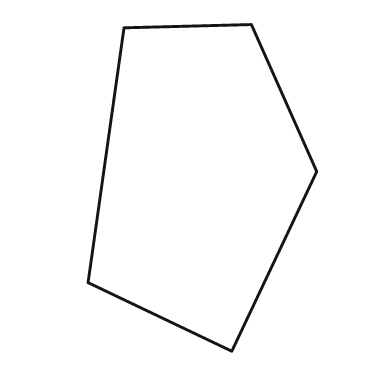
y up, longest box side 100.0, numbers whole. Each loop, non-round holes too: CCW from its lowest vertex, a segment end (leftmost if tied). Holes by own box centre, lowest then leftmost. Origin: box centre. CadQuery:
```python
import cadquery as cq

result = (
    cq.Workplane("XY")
    .moveTo(9.0, -50.0)
    .lineTo(35.0, 5.0)
    .lineTo(15.0, 50.0)
    .lineTo(-24.0, 49.0)
    .lineTo(-35.0, -29.0)
    .close()
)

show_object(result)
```